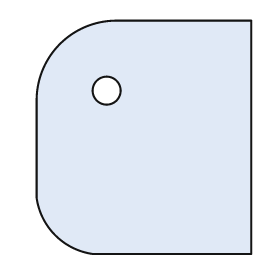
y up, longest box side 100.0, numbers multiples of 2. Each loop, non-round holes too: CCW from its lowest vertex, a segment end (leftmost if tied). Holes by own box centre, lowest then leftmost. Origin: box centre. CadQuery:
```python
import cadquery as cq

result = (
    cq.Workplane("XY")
    .moveTo(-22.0, -50.0)
    .lineTo(46.0, -50.0)
    .lineTo(46.0, 50.0)
    .lineTo(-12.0, 50.0)
    .threePointArc((-36.0, 40.0), (-46.0, 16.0))
    .lineTo(-46.0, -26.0)
    .threePointArc((-38.0, -42.0), (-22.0, -50.0))
    .close()
    .moveTo(-16.0, 20.0)
    .circle(6.0)
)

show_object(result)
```